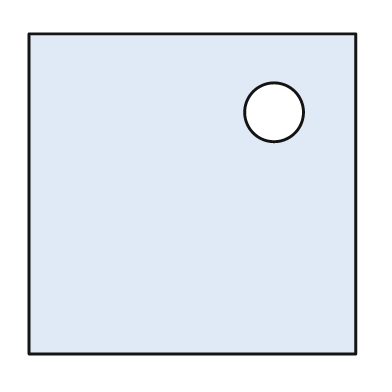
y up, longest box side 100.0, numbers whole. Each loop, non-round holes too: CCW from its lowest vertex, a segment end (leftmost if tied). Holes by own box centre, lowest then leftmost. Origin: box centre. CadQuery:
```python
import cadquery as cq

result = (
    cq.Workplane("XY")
    .moveTo(-50.0, -49.0)
    .lineTo(50.0, -49.0)
    .lineTo(50.0, 49.0)
    .lineTo(-50.0, 49.0)
    .close()
    .moveTo(25.0, 25.0)
    .circle(9.0)
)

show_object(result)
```